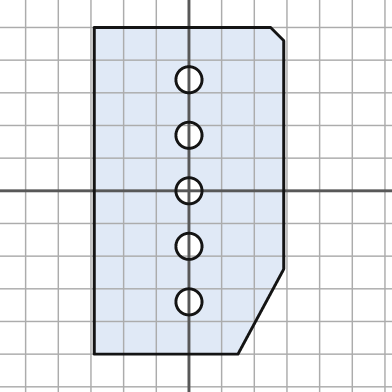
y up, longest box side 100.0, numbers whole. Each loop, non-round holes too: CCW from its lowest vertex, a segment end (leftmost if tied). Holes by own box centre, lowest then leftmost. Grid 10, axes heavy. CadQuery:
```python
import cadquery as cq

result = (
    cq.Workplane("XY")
    .moveTo(-29.0, -50.0)
    .lineTo(15.0, -50.0)
    .lineTo(29.0, -24.0)
    .lineTo(29.0, 46.0)
    .lineTo(25.0, 50.0)
    .lineTo(-29.0, 50.0)
    .close()
    .moveTo(0.0, -34.0)
    .circle(4.0)
    .moveTo(0.0, -17.0)
    .circle(4.0)
    .moveTo(0.0, 0.0)
    .circle(4.0)
    .moveTo(0.0, 17.0)
    .circle(4.0)
    .moveTo(0.0, 34.0)
    .circle(4.0)
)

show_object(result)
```